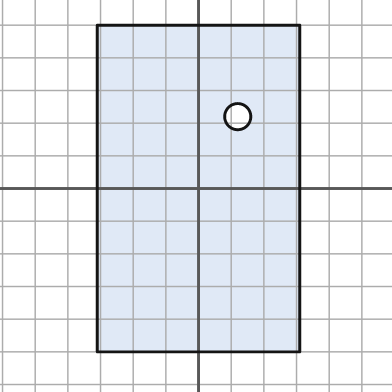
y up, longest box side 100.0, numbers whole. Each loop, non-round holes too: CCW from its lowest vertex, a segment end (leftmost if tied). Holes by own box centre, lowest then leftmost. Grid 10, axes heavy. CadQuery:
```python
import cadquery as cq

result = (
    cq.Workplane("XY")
    .moveTo(-31.0, -50.0)
    .lineTo(31.0, -50.0)
    .lineTo(31.0, 50.0)
    .lineTo(-31.0, 50.0)
    .close()
    .moveTo(12.0, 22.0)
    .circle(4.0)
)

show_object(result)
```